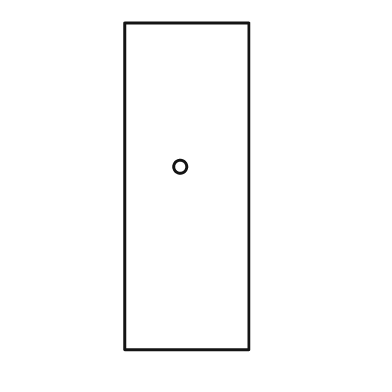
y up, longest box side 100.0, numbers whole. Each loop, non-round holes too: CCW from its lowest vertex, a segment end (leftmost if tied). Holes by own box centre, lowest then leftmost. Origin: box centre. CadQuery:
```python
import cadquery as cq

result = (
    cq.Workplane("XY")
    .moveTo(-19.0, -50.0)
    .lineTo(19.0, -50.0)
    .lineTo(19.0, 50.0)
    .lineTo(-19.0, 50.0)
    .close()
    .moveTo(-2.0, 6.0)
    .circle(2.0)
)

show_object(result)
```